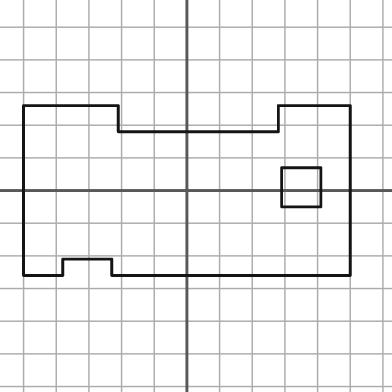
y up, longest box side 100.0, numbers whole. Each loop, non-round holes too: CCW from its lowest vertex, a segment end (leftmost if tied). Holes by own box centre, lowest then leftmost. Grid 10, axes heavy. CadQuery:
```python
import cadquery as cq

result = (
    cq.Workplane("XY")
    .moveTo(-50.0, -26.0)
    .lineTo(-38.0, -26.0)
    .lineTo(-38.0, -21.0)
    .lineTo(-23.0, -21.0)
    .lineTo(-23.0, -26.0)
    .lineTo(50.0, -26.0)
    .lineTo(50.0, 26.0)
    .lineTo(28.0, 26.0)
    .lineTo(28.0, 18.0)
    .lineTo(-21.0, 18.0)
    .lineTo(-21.0, 26.0)
    .lineTo(-50.0, 26.0)
    .close()
    .moveTo(29.0, -5.0)
    .lineTo(41.0, -5.0)
    .lineTo(41.0, 7.0)
    .lineTo(29.0, 7.0)
    .close()
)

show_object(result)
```